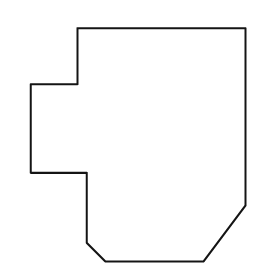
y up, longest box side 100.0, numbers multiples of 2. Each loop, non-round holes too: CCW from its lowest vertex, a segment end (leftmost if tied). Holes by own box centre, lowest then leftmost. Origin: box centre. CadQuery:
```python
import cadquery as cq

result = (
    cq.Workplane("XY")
    .moveTo(-14.0, -50.0)
    .lineTo(28.0, -50.0)
    .lineTo(46.0, -26.0)
    .lineTo(46.0, 50.0)
    .lineTo(-26.0, 50.0)
    .lineTo(-26.0, 26.0)
    .lineTo(-46.0, 26.0)
    .lineTo(-46.0, -12.0)
    .lineTo(-22.0, -12.0)
    .lineTo(-22.0, -42.0)
    .close()
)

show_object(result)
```